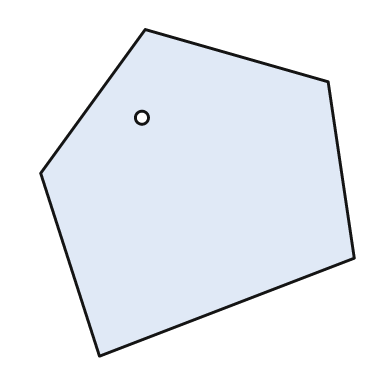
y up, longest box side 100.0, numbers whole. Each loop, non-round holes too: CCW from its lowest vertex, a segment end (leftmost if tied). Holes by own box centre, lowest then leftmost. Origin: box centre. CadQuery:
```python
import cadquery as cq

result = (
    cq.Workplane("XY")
    .moveTo(-30.0, -50.0)
    .lineTo(48.0, -20.0)
    .lineTo(40.0, 34.0)
    .lineTo(-16.0, 50.0)
    .lineTo(-48.0, 6.0)
    .close()
    .moveTo(-17.0, 23.0)
    .circle(2.0)
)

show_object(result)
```